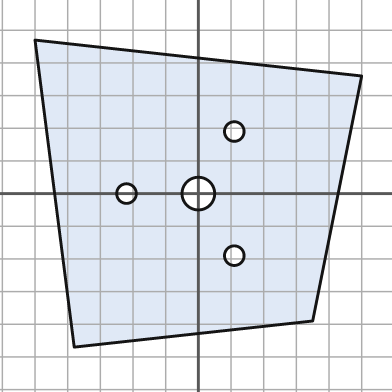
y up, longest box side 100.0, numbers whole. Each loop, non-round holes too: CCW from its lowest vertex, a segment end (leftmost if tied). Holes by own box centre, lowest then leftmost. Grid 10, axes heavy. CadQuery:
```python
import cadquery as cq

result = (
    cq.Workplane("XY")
    .moveTo(-38.0, -47.0)
    .lineTo(35.0, -39.0)
    .lineTo(50.0, 36.0)
    .lineTo(-50.0, 47.0)
    .close()
    .moveTo(11.0, -19.0)
    .circle(3.0)
    .moveTo(-22.0, 0.0)
    .circle(3.0)
    .moveTo(0.0, 0.0)
    .circle(5.0)
    .moveTo(11.0, 19.0)
    .circle(3.0)
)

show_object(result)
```